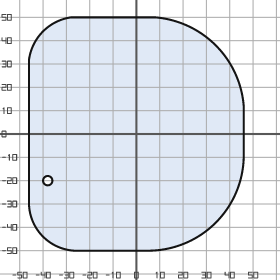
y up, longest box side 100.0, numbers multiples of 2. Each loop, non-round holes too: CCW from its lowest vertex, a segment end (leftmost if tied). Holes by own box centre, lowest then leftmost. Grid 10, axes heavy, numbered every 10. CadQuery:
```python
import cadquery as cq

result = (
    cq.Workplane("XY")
    .moveTo(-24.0, -50.0)
    .lineTo(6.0, -50.0)
    .threePointArc((34.0, -38.0), (46.0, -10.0))
    .lineTo(46.0, 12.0)
    .threePointArc((34.0, 38.0), (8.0, 50.0))
    .lineTo(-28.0, 50.0)
    .threePointArc((-40.0, 44.0), (-46.0, 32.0))
    .lineTo(-46.0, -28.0)
    .threePointArc((-40.0, -44.0), (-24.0, -50.0))
    .close()
    .moveTo(-38.0, -20.0)
    .circle(2.0)
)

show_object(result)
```